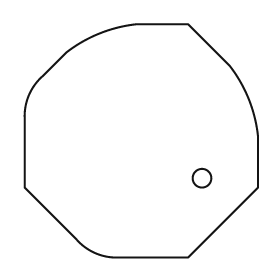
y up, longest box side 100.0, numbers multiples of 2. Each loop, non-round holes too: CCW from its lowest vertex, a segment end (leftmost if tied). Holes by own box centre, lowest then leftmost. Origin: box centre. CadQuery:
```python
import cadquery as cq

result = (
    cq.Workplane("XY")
    .moveTo(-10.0, -50.0)
    .lineTo(20.0, -50.0)
    .lineTo(50.0, -20.0)
    .lineTo(50.0, 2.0)
    .threePointArc((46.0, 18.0), (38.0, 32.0))
    .lineTo(20.0, 50.0)
    .lineTo(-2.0, 50.0)
    .threePointArc((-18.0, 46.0), (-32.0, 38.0))
    .lineTo(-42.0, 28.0)
    .threePointArc((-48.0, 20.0), (-50.0, 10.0))
    .lineTo(-50.0, -20.0)
    .lineTo(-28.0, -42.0)
    .threePointArc((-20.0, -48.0), (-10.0, -50.0))
    .close()
    .moveTo(26.0, -16.0)
    .circle(4.0)
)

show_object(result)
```